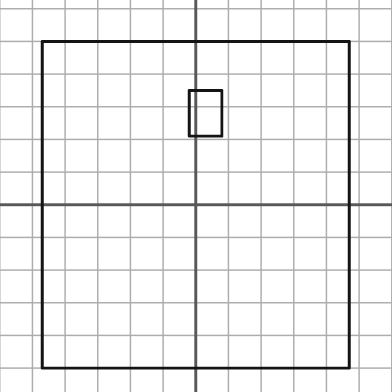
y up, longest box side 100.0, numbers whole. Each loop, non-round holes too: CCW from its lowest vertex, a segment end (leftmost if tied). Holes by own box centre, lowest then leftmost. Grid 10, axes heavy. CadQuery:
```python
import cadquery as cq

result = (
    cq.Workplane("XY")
    .moveTo(-47.0, -50.0)
    .lineTo(47.0, -50.0)
    .lineTo(47.0, 50.0)
    .lineTo(-47.0, 50.0)
    .close()
    .moveTo(-2.0, 21.0)
    .lineTo(8.0, 21.0)
    .lineTo(8.0, 35.0)
    .lineTo(-2.0, 35.0)
    .close()
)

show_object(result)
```